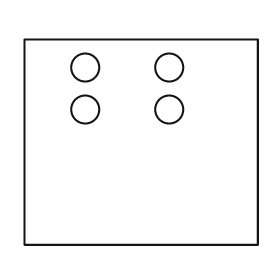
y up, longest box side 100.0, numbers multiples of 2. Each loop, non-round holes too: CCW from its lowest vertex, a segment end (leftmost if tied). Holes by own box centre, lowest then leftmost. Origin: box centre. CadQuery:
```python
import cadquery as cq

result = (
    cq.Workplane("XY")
    .moveTo(-50.0, -44.0)
    .lineTo(50.0, -44.0)
    .lineTo(50.0, 44.0)
    .lineTo(-50.0, 44.0)
    .close()
    .moveTo(-24.0, 14.0)
    .circle(6.0)
    .moveTo(12.0, 14.0)
    .circle(6.0)
    .moveTo(-24.0, 32.0)
    .circle(6.0)
    .moveTo(12.0, 32.0)
    .circle(6.0)
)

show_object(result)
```